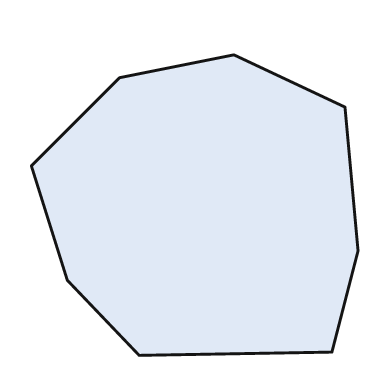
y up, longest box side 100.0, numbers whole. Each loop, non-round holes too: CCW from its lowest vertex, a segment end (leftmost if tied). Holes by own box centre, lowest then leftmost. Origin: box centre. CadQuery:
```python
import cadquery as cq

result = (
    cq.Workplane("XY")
    .moveTo(-17.0, -46.0)
    .lineTo(42.0, -45.0)
    .lineTo(50.0, -14.0)
    .lineTo(46.0, 30.0)
    .lineTo(12.0, 46.0)
    .lineTo(-23.0, 39.0)
    .lineTo(-50.0, 12.0)
    .lineTo(-39.0, -23.0)
    .close()
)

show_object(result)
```